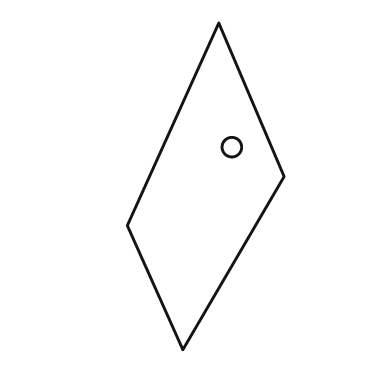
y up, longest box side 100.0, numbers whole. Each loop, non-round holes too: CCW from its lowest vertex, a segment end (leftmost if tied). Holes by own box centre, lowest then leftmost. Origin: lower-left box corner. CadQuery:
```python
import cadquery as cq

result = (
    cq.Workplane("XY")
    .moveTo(17.0, 0.0)
    .lineTo(48.0, 53.0)
    .lineTo(28.0, 100.0)
    .lineTo(0.0, 38.0)
    .close()
    .moveTo(32.0, 62.0)
    .circle(3.0)
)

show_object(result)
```